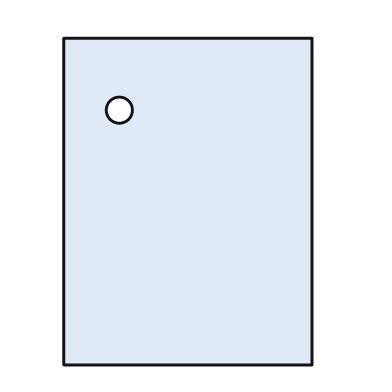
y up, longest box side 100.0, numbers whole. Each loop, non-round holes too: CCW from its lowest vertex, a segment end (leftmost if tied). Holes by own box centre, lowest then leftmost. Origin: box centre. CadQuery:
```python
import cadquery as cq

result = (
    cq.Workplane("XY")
    .moveTo(-38.0, -50.0)
    .lineTo(38.0, -50.0)
    .lineTo(38.0, 50.0)
    .lineTo(-38.0, 50.0)
    .close()
    .moveTo(-21.0, 28.0)
    .circle(4.0)
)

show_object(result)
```